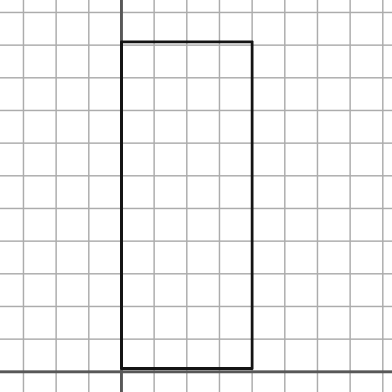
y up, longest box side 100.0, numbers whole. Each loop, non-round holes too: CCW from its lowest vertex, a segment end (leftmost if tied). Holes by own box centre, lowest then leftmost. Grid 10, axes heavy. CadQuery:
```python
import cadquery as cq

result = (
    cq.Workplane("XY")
    .moveTo(0.0, 1.0)
    .lineTo(40.0, 1.0)
    .lineTo(40.0, 101.0)
    .lineTo(0.0, 101.0)
    .close()
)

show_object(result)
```